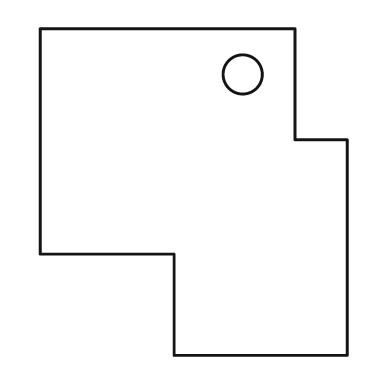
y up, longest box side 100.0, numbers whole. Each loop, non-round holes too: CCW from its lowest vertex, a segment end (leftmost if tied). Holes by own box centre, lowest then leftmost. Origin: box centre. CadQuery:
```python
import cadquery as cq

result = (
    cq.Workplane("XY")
    .moveTo(-6.0, -50.0)
    .lineTo(47.0, -50.0)
    .lineTo(47.0, 16.0)
    .lineTo(31.0, 16.0)
    .lineTo(31.0, 50.0)
    .lineTo(-47.0, 50.0)
    .lineTo(-47.0, -19.0)
    .lineTo(-6.0, -19.0)
    .close()
    .moveTo(15.0, 36.0)
    .circle(6.0)
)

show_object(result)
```